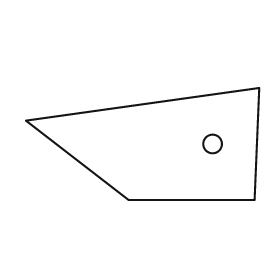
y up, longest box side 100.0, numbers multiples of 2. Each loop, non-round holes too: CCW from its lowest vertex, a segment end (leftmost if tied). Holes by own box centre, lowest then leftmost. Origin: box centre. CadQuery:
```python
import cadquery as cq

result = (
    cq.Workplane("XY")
    .moveTo(-6.0, -24.0)
    .lineTo(48.0, -24.0)
    .lineTo(50.0, 24.0)
    .lineTo(-50.0, 10.0)
    .close()
    .moveTo(30.0, 0.0)
    .circle(4.0)
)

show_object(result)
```